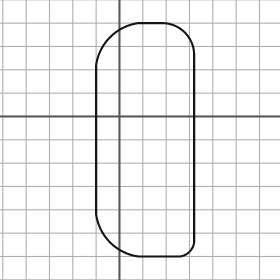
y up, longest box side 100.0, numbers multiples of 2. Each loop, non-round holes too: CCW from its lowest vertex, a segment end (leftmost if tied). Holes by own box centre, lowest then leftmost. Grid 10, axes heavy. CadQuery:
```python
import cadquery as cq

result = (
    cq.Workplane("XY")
    .moveTo(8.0, -60.0)
    .lineTo(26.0, -60.0)
    .threePointArc((30.0, -58.0), (32.0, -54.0))
    .lineTo(32.0, 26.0)
    .threePointArc((28.0, 36.0), (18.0, 40.0))
    .lineTo(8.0, 40.0)
    .threePointArc((-4.0, 34.0), (-10.0, 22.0))
    .lineTo(-10.0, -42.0)
    .threePointArc((-4.0, -54.0), (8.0, -60.0))
    .close()
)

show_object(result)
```